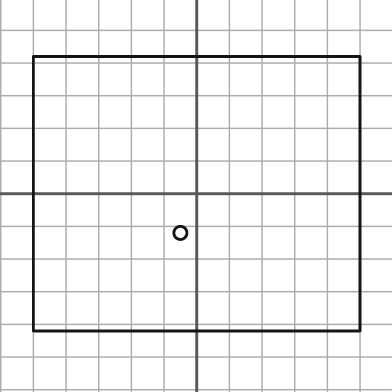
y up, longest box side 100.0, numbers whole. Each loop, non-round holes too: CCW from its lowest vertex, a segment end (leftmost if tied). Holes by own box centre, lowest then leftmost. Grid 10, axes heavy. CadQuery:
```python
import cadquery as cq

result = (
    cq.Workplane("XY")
    .moveTo(-50.0, -42.0)
    .lineTo(50.0, -42.0)
    .lineTo(50.0, 42.0)
    .lineTo(-50.0, 42.0)
    .close()
    .moveTo(-5.0, -12.0)
    .circle(2.0)
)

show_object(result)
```